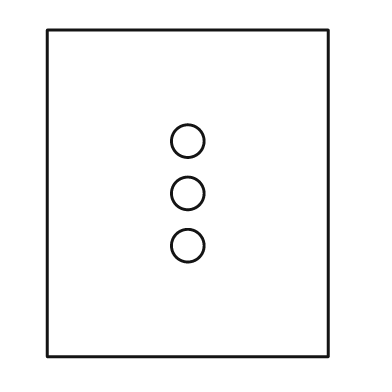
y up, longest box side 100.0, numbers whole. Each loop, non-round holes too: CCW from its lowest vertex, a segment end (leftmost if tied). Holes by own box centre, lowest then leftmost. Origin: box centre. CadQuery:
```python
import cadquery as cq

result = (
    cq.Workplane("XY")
    .moveTo(-43.0, -50.0)
    .lineTo(43.0, -50.0)
    .lineTo(43.0, 50.0)
    .lineTo(-43.0, 50.0)
    .close()
    .moveTo(0.0, -16.0)
    .circle(5.0)
    .moveTo(0.0, 0.0)
    .circle(5.0)
    .moveTo(0.0, 16.0)
    .circle(5.0)
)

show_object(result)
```